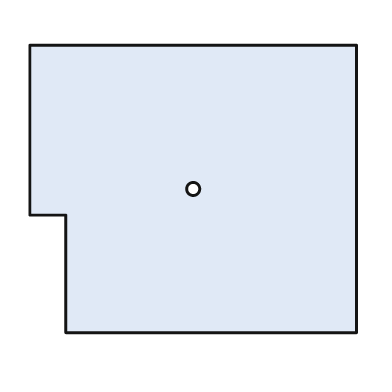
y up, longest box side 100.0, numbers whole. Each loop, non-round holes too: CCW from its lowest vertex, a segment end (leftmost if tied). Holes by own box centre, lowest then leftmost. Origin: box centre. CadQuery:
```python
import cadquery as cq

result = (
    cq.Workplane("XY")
    .moveTo(-39.0, -44.0)
    .lineTo(50.0, -44.0)
    .lineTo(50.0, 44.0)
    .lineTo(-50.0, 44.0)
    .lineTo(-50.0, -8.0)
    .lineTo(-39.0, -8.0)
    .close()
    .moveTo(0.0, 0.0)
    .circle(2.0)
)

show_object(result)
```